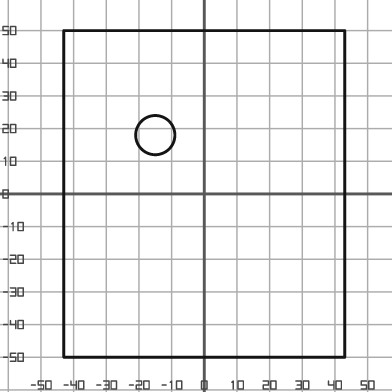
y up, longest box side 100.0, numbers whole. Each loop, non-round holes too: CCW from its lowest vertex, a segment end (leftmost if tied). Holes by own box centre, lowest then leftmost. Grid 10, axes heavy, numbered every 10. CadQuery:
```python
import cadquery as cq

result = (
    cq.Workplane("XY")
    .moveTo(-43.0, -50.0)
    .lineTo(43.0, -50.0)
    .lineTo(43.0, 50.0)
    .lineTo(-43.0, 50.0)
    .close()
    .moveTo(-15.0, 18.0)
    .circle(6.0)
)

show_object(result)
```